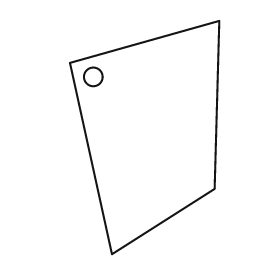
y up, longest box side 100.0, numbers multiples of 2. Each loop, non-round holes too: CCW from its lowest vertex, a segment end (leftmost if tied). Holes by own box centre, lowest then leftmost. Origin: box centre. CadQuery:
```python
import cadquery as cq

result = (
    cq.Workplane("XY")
    .moveTo(-14.0, -50.0)
    .lineTo(30.0, -22.0)
    .lineTo(32.0, 50.0)
    .lineTo(-32.0, 32.0)
    .close()
    .moveTo(-22.0, 26.0)
    .circle(4.0)
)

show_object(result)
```